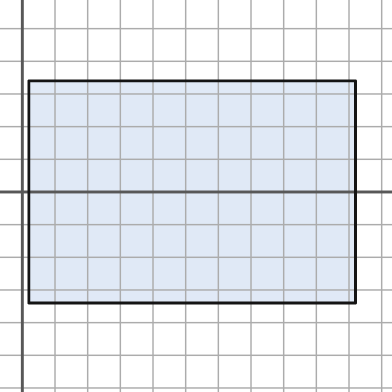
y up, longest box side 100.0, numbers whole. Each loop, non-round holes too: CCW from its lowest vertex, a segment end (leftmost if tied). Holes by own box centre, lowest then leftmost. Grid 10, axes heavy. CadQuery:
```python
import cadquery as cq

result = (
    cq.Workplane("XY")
    .moveTo(2.0, -34.0)
    .lineTo(102.0, -34.0)
    .lineTo(102.0, 34.0)
    .lineTo(2.0, 34.0)
    .close()
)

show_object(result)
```